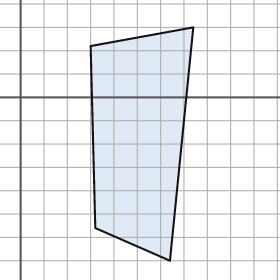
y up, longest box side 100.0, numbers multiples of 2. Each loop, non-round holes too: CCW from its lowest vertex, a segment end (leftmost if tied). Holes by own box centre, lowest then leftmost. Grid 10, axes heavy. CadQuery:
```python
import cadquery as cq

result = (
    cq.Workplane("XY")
    .moveTo(64.0, -70.0)
    .lineTo(74.0, 30.0)
    .lineTo(30.0, 22.0)
    .lineTo(32.0, -56.0)
    .close()
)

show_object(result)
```